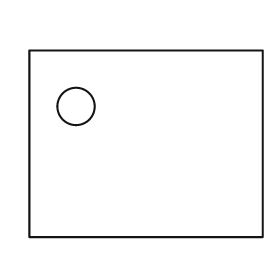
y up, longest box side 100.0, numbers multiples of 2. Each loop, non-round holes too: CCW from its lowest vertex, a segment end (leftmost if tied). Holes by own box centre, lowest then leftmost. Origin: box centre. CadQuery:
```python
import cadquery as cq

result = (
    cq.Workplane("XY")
    .moveTo(-50.0, -40.0)
    .lineTo(50.0, -40.0)
    .lineTo(50.0, 40.0)
    .lineTo(-50.0, 40.0)
    .close()
    .moveTo(-30.0, 16.0)
    .circle(8.0)
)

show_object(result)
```